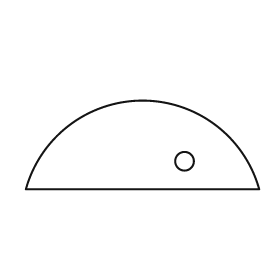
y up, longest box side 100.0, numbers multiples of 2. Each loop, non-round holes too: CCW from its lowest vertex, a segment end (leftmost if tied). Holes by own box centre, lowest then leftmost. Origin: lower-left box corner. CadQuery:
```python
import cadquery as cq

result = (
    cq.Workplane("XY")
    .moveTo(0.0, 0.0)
    .lineTo(100.0, 0.0)
    .threePointArc((50.0, 38.0), (0.0, 0.0))
    .close()
    .moveTo(68.0, 12.0)
    .circle(4.0)
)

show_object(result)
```